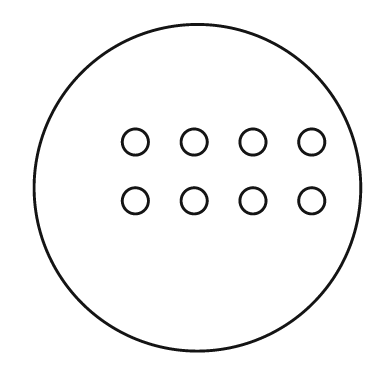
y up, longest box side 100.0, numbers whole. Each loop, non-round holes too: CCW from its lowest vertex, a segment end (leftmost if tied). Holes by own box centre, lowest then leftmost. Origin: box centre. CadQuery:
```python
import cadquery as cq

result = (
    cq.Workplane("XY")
    .moveTo(0.0, 0.0)
    .circle(50.0)
    .moveTo(-19.0, -4.0)
    .circle(4.0)
    .moveTo(-1.0, -4.0)
    .circle(4.0)
    .moveTo(17.0, -4.0)
    .circle(4.0)
    .moveTo(35.0, -4.0)
    .circle(4.0)
    .moveTo(-19.0, 14.0)
    .circle(4.0)
    .moveTo(-1.0, 14.0)
    .circle(4.0)
    .moveTo(17.0, 14.0)
    .circle(4.0)
    .moveTo(35.0, 14.0)
    .circle(4.0)
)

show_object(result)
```